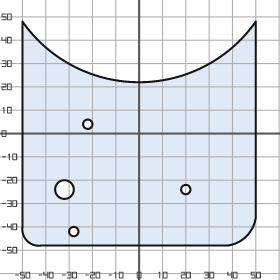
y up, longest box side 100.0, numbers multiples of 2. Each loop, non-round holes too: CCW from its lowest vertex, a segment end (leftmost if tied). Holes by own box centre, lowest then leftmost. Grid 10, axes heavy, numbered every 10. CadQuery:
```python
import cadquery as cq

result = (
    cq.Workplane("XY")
    .moveTo(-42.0, -48.0)
    .lineTo(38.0, -48.0)
    .threePointArc((46.0, -44.0), (50.0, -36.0))
    .lineTo(50.0, 48.0)
    .threePointArc((0.0, 22.0), (-50.0, 48.0))
    .lineTo(-50.0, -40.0)
    .threePointArc((-48.0, -46.0), (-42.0, -48.0))
    .close()
    .moveTo(-28.0, -42.0)
    .circle(2.0)
    .moveTo(-32.0, -24.0)
    .circle(4.0)
    .moveTo(20.0, -24.0)
    .circle(2.0)
    .moveTo(-22.0, 4.0)
    .circle(2.0)
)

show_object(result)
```